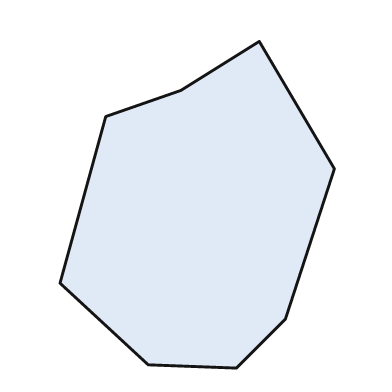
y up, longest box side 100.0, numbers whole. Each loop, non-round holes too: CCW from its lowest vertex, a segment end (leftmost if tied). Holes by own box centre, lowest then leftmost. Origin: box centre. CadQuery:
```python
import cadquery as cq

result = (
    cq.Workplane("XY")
    .moveTo(12.0, -50.0)
    .lineTo(27.0, -35.0)
    .lineTo(42.0, 11.0)
    .lineTo(19.0, 50.0)
    .lineTo(-5.0, 35.0)
    .lineTo(-28.0, 27.0)
    .lineTo(-42.0, -24.0)
    .lineTo(-15.0, -49.0)
    .close()
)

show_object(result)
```